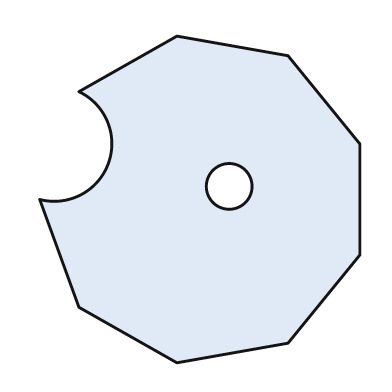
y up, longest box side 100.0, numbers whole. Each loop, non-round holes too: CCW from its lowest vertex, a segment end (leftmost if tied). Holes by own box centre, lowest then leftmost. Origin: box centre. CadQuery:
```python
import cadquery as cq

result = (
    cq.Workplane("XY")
    .moveTo(-7.0, -50.0)
    .lineTo(27.0, -44.0)
    .lineTo(49.0, -17.0)
    .lineTo(49.0, 17.0)
    .lineTo(27.0, 44.0)
    .lineTo(-7.0, 50.0)
    .lineTo(-37.0, 33.0)
    .threePointArc((-28.0, 11.0), (-49.0, 0.0))
    .lineTo(-37.0, -33.0)
    .close()
    .moveTo(9.0, 4.0)
    .circle(7.0)
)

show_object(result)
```